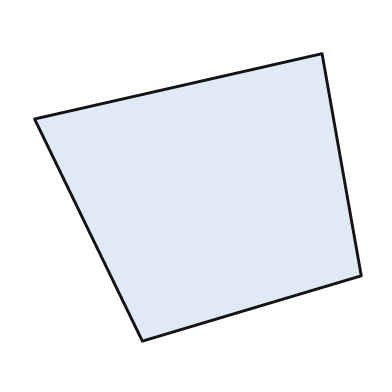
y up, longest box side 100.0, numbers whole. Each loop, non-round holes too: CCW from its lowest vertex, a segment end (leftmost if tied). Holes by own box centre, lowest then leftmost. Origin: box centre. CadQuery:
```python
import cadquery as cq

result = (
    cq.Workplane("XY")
    .moveTo(-17.0, -44.0)
    .lineTo(50.0, -24.0)
    .lineTo(38.0, 44.0)
    .lineTo(-50.0, 24.0)
    .close()
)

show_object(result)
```